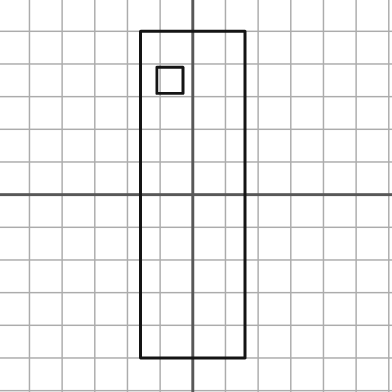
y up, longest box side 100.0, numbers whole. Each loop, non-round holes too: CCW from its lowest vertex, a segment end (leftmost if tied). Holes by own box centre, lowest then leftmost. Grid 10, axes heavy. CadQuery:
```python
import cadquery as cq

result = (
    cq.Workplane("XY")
    .moveTo(-16.0, -50.0)
    .lineTo(16.0, -50.0)
    .lineTo(16.0, 50.0)
    .lineTo(-16.0, 50.0)
    .close()
    .moveTo(-11.0, 31.0)
    .lineTo(-3.0, 31.0)
    .lineTo(-3.0, 39.0)
    .lineTo(-11.0, 39.0)
    .close()
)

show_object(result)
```